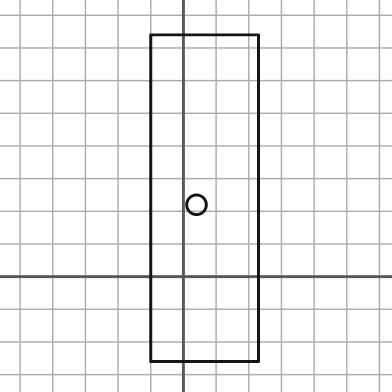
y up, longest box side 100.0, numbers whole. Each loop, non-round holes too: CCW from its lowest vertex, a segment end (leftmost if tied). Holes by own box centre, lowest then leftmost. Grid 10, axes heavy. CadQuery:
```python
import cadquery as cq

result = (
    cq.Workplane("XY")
    .moveTo(-10.0, -26.0)
    .lineTo(23.0, -26.0)
    .lineTo(23.0, 74.0)
    .lineTo(-10.0, 74.0)
    .close()
    .moveTo(4.0, 22.0)
    .circle(3.0)
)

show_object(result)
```